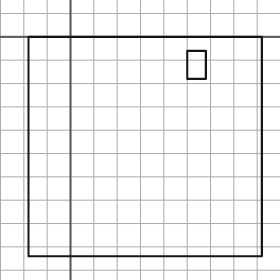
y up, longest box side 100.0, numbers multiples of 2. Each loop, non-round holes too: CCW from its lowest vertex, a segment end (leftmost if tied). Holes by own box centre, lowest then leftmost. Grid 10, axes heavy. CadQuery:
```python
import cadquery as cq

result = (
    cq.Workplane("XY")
    .moveTo(-18.0, -94.0)
    .lineTo(82.0, -94.0)
    .lineTo(82.0, 0.0)
    .lineTo(-18.0, 0.0)
    .close()
    .moveTo(50.0, -18.0)
    .lineTo(58.0, -18.0)
    .lineTo(58.0, -6.0)
    .lineTo(50.0, -6.0)
    .close()
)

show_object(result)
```